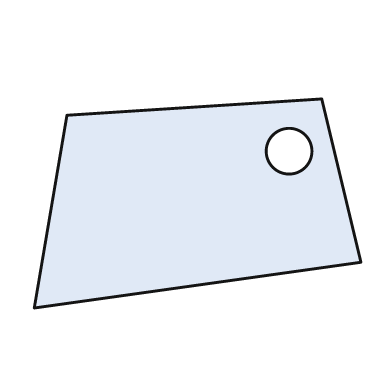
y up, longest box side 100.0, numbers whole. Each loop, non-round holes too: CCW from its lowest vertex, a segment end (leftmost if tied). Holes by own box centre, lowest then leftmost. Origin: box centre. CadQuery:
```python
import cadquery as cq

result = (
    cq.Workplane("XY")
    .moveTo(-50.0, -32.0)
    .lineTo(50.0, -18.0)
    .lineTo(38.0, 32.0)
    .lineTo(-40.0, 27.0)
    .close()
    .moveTo(28.0, 16.0)
    .circle(7.0)
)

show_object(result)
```